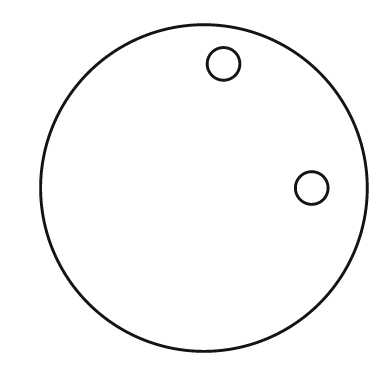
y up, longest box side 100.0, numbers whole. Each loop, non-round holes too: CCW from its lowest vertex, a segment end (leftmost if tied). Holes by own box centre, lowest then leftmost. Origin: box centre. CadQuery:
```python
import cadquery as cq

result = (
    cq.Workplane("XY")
    .moveTo(0.0, 0.0)
    .circle(50.0)
    .moveTo(33.0, 0.0)
    .circle(5.0)
    .moveTo(6.0, 38.0)
    .circle(5.0)
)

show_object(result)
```